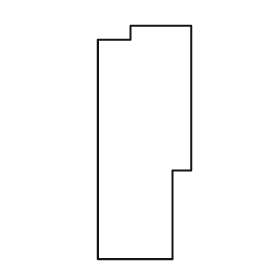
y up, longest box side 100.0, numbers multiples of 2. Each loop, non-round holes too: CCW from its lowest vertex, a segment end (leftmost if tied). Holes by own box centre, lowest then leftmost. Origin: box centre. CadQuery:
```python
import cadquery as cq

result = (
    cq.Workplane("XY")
    .moveTo(-20.0, -50.0)
    .lineTo(12.0, -50.0)
    .lineTo(12.0, -12.0)
    .lineTo(20.0, -12.0)
    .lineTo(20.0, 50.0)
    .lineTo(-6.0, 50.0)
    .lineTo(-6.0, 44.0)
    .lineTo(-20.0, 44.0)
    .close()
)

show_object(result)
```